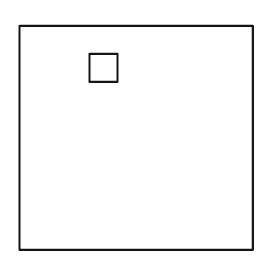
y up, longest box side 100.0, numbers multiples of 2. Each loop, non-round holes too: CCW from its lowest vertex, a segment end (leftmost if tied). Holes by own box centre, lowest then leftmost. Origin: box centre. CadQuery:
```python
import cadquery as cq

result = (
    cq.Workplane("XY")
    .moveTo(-50.0, -48.0)
    .lineTo(50.0, -48.0)
    .lineTo(50.0, 48.0)
    .lineTo(-50.0, 48.0)
    .close()
    .moveTo(-20.0, 24.0)
    .lineTo(-8.0, 24.0)
    .lineTo(-8.0, 36.0)
    .lineTo(-20.0, 36.0)
    .close()
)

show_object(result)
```